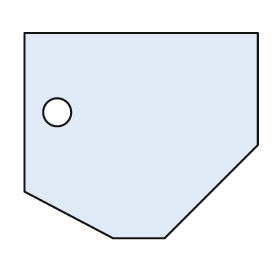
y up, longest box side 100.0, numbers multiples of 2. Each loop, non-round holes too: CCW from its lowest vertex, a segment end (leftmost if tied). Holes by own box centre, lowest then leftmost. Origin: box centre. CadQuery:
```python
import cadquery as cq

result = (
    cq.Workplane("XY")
    .moveTo(-12.0, -44.0)
    .lineTo(10.0, -44.0)
    .lineTo(50.0, -4.0)
    .lineTo(50.0, 44.0)
    .lineTo(-50.0, 44.0)
    .lineTo(-50.0, -24.0)
    .close()
    .moveTo(-36.0, 10.0)
    .circle(6.0)
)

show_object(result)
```